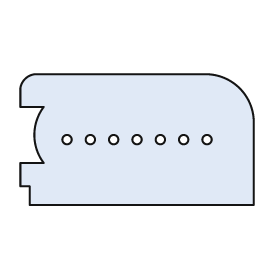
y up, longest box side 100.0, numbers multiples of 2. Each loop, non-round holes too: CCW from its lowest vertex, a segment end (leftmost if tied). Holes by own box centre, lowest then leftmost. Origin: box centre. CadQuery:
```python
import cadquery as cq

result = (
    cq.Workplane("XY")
    .moveTo(-46.0, -28.0)
    .lineTo(50.0, -28.0)
    .lineTo(50.0, 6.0)
    .threePointArc((44.0, 22.0), (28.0, 28.0))
    .lineTo(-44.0, 28.0)
    .threePointArc((-48.0, 26.0), (-50.0, 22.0))
    .lineTo(-50.0, 14.0)
    .lineTo(-40.0, 14.0)
    .threePointArc((-44.0, 2.0), (-40.0, -10.0))
    .lineTo(-50.0, -10.0)
    .lineTo(-50.0, -20.0)
    .lineTo(-46.0, -20.0)
    .close()
    .moveTo(-30.0, 0.0)
    .circle(2.0)
    .moveTo(-20.0, 0.0)
    .circle(2.0)
    .moveTo(-10.0, 0.0)
    .circle(2.0)
    .moveTo(0.0, 0.0)
    .circle(2.0)
    .moveTo(10.0, 0.0)
    .circle(2.0)
    .moveTo(20.0, 0.0)
    .circle(2.0)
    .moveTo(30.0, 0.0)
    .circle(2.0)
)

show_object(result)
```